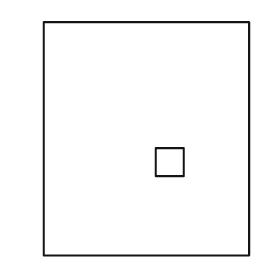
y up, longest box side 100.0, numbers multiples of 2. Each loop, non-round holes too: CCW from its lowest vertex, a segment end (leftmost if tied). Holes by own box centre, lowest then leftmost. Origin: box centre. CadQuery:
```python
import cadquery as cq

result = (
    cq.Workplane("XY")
    .moveTo(-44.0, -50.0)
    .lineTo(44.0, -50.0)
    .lineTo(44.0, 50.0)
    .lineTo(-44.0, 50.0)
    .close()
    .moveTo(4.0, -16.0)
    .lineTo(16.0, -16.0)
    .lineTo(16.0, -4.0)
    .lineTo(4.0, -4.0)
    .close()
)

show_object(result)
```